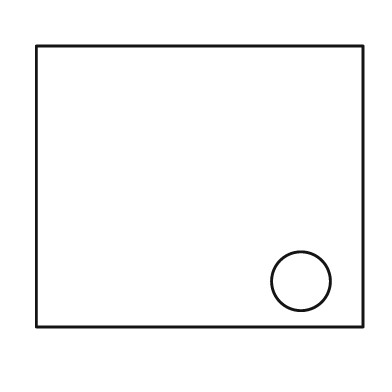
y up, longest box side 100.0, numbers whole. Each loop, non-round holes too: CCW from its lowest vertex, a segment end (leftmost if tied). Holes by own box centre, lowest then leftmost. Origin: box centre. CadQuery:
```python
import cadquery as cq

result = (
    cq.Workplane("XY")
    .moveTo(-50.0, -43.0)
    .lineTo(50.0, -43.0)
    .lineTo(50.0, 43.0)
    .lineTo(-50.0, 43.0)
    .close()
    .moveTo(31.0, -29.0)
    .circle(9.0)
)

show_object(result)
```